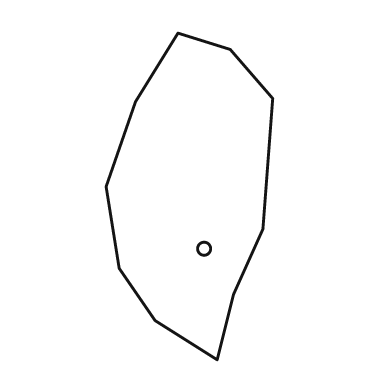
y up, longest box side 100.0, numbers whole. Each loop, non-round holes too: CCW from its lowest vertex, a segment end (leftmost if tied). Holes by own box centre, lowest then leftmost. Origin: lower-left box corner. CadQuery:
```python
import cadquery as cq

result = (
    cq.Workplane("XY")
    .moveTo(34.0, 0.0)
    .lineTo(39.0, 20.0)
    .lineTo(48.0, 40.0)
    .lineTo(51.0, 80.0)
    .lineTo(38.0, 95.0)
    .lineTo(22.0, 100.0)
    .lineTo(9.0, 79.0)
    .lineTo(0.0, 53.0)
    .lineTo(4.0, 28.0)
    .lineTo(15.0, 12.0)
    .close()
    .moveTo(30.0, 34.0)
    .circle(2.0)
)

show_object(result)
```